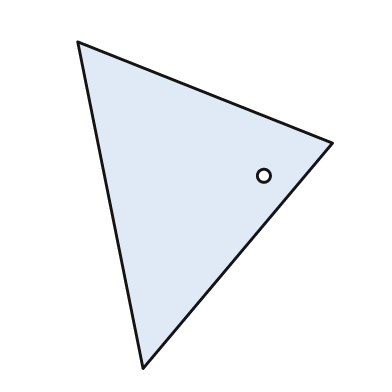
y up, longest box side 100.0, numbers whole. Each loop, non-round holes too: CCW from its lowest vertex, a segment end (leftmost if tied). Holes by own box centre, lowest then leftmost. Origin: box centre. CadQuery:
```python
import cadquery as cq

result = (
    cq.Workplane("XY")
    .moveTo(-19.0, -50.0)
    .lineTo(39.0, 19.0)
    .lineTo(-39.0, 50.0)
    .close()
    .moveTo(18.0, 9.0)
    .circle(2.0)
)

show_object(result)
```